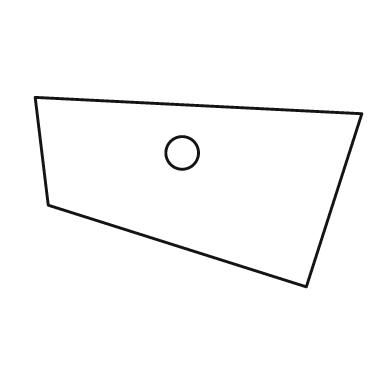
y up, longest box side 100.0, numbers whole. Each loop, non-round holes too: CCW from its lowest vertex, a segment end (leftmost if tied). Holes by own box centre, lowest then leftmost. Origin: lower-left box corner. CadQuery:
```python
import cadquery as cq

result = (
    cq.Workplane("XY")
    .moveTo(83.0, 0.0)
    .lineTo(100.0, 53.0)
    .lineTo(0.0, 58.0)
    .lineTo(4.0, 25.0)
    .close()
    .moveTo(45.0, 41.0)
    .circle(5.0)
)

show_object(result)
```